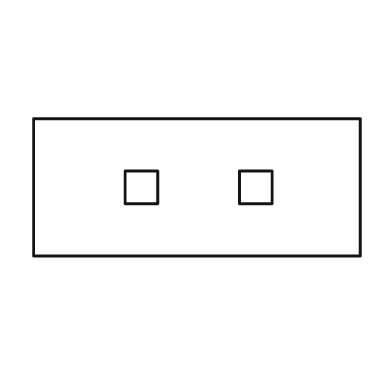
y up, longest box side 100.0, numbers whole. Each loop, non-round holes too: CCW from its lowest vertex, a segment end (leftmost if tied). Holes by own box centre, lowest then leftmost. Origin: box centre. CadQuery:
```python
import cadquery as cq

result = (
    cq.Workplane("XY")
    .moveTo(-50.0, -21.0)
    .lineTo(50.0, -21.0)
    .lineTo(50.0, 21.0)
    .lineTo(-50.0, 21.0)
    .close()
    .moveTo(-22.0, -5.0)
    .lineTo(-12.0, -5.0)
    .lineTo(-12.0, 5.0)
    .lineTo(-22.0, 5.0)
    .close()
    .moveTo(13.0, -5.0)
    .lineTo(23.0, -5.0)
    .lineTo(23.0, 5.0)
    .lineTo(13.0, 5.0)
    .close()
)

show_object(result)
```